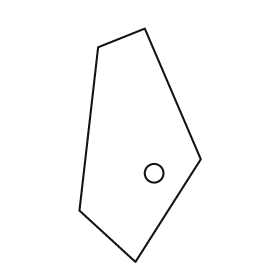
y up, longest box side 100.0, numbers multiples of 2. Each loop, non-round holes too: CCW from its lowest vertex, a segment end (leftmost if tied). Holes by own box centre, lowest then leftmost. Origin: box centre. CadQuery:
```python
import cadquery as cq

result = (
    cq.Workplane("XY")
    .moveTo(-2.0, -50.0)
    .lineTo(26.0, -6.0)
    .lineTo(2.0, 50.0)
    .lineTo(-18.0, 42.0)
    .lineTo(-26.0, -28.0)
    .close()
    .moveTo(6.0, -12.0)
    .circle(4.0)
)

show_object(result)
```